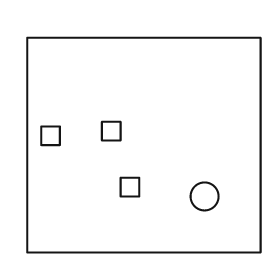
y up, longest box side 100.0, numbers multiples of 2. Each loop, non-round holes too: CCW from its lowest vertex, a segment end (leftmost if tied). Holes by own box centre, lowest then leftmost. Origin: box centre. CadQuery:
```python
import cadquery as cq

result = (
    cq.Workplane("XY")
    .moveTo(-50.0, -46.0)
    .lineTo(50.0, -46.0)
    .lineTo(50.0, 46.0)
    .lineTo(-50.0, 46.0)
    .close()
    .moveTo(26.0, -22.0)
    .circle(6.0)
    .moveTo(-10.0, -22.0)
    .lineTo(-2.0, -22.0)
    .lineTo(-2.0, -14.0)
    .lineTo(-10.0, -14.0)
    .close()
    .moveTo(-44.0, 0.0)
    .lineTo(-36.0, 0.0)
    .lineTo(-36.0, 8.0)
    .lineTo(-44.0, 8.0)
    .close()
    .moveTo(-18.0, 2.0)
    .lineTo(-10.0, 2.0)
    .lineTo(-10.0, 10.0)
    .lineTo(-18.0, 10.0)
    .close()
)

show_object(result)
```